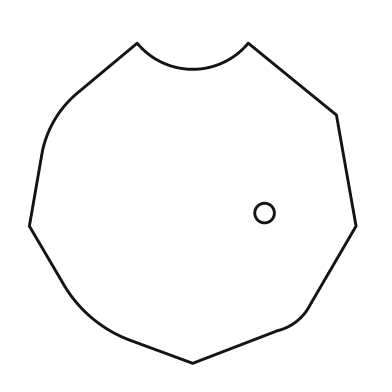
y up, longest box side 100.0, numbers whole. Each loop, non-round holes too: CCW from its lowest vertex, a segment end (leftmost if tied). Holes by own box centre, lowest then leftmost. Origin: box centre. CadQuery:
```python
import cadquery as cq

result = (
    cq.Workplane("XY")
    .moveTo(0.0, -49.0)
    .lineTo(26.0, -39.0)
    .threePointArc((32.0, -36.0), (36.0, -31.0))
    .lineTo(50.0, -7.0)
    .lineTo(44.0, 27.0)
    .lineTo(17.0, 49.0)
    .threePointArc((0.0, 41.0), (-17.0, 49.0))
    .lineTo(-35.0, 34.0)
    .threePointArc((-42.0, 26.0), (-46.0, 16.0))
    .lineTo(-50.0, -7.0)
    .lineTo(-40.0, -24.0)
    .threePointArc((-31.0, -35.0), (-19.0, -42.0))
    .close()
    .moveTo(22.0, -3.0)
    .circle(3.0)
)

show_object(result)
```